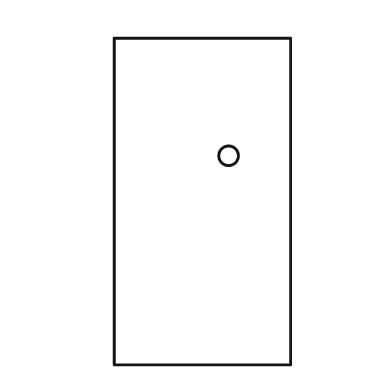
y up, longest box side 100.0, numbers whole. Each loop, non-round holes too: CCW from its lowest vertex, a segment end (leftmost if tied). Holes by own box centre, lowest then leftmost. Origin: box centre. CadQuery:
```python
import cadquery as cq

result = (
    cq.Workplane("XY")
    .moveTo(-27.0, -50.0)
    .lineTo(27.0, -50.0)
    .lineTo(27.0, 50.0)
    .lineTo(-27.0, 50.0)
    .close()
    .moveTo(8.0, 14.0)
    .circle(3.0)
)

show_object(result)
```